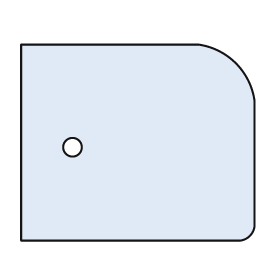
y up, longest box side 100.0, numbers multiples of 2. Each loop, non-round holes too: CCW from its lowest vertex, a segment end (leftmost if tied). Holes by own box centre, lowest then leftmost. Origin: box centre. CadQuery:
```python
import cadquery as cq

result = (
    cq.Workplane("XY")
    .moveTo(-50.0, -42.0)
    .lineTo(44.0, -42.0)
    .threePointArc((48.0, -40.0), (50.0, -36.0))
    .lineTo(50.0, 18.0)
    .threePointArc((42.0, 34.0), (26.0, 42.0))
    .lineTo(-50.0, 42.0)
    .close()
    .moveTo(-28.0, -2.0)
    .circle(4.0)
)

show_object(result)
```